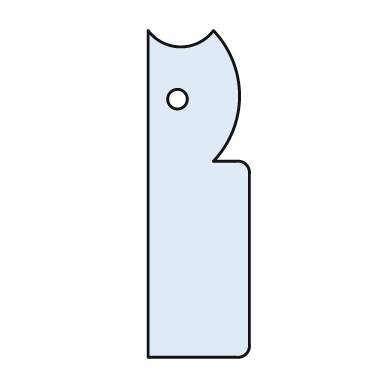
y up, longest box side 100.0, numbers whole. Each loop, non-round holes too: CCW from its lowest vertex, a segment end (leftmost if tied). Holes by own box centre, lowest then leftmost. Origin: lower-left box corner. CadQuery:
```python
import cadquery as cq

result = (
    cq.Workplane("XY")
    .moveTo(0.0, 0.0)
    .lineTo(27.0, 0.0)
    .threePointArc((30.0, 1.0), (31.0, 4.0))
    .lineTo(31.0, 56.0)
    .threePointArc((30.0, 59.0), (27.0, 60.0))
    .lineTo(20.0, 60.0)
    .threePointArc((28.0, 80.0), (20.0, 100.0))
    .threePointArc((10.0, 95.0), (0.0, 100.0))
    .close()
    .moveTo(9.0, 79.0)
    .circle(3.0)
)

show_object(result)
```